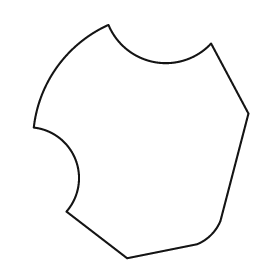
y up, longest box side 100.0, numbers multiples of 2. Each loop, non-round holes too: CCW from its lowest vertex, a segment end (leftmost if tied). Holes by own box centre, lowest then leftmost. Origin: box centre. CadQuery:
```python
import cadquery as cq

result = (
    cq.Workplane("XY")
    .moveTo(-6.0, -50.0)
    .lineTo(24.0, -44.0)
    .threePointArc((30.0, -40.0), (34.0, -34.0))
    .lineTo(46.0, 12.0)
    .lineTo(30.0, 42.0)
    .threePointArc((6.0, 34.0), (-14.0, 50.0))
    .threePointArc((-36.0, 32.0), (-46.0, 6.0))
    .threePointArc((-28.0, -8.0), (-32.0, -30.0))
    .close()
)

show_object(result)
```